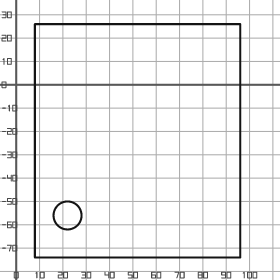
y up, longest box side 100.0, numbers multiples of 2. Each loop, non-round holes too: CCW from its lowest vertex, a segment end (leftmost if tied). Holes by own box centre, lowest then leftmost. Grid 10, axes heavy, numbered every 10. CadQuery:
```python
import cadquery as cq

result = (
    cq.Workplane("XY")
    .moveTo(8.0, -74.0)
    .lineTo(96.0, -74.0)
    .lineTo(96.0, 26.0)
    .lineTo(8.0, 26.0)
    .close()
    .moveTo(22.0, -56.0)
    .circle(6.0)
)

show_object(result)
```